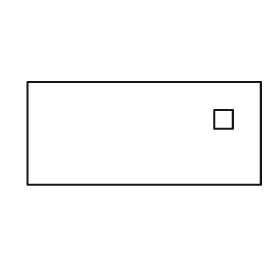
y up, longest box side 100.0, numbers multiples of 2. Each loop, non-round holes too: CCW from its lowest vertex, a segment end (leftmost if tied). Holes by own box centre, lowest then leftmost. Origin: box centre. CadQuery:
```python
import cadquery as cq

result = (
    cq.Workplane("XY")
    .moveTo(-50.0, -22.0)
    .lineTo(50.0, -22.0)
    .lineTo(50.0, 22.0)
    .lineTo(-50.0, 22.0)
    .close()
    .moveTo(30.0, 2.0)
    .lineTo(38.0, 2.0)
    .lineTo(38.0, 10.0)
    .lineTo(30.0, 10.0)
    .close()
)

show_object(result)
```